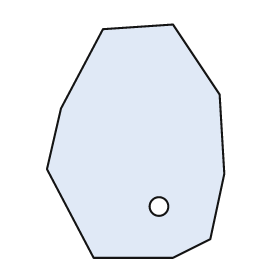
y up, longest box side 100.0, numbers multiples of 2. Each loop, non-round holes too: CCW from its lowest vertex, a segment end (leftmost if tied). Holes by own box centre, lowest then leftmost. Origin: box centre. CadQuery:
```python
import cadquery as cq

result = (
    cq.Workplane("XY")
    .moveTo(-18.0, -50.0)
    .lineTo(16.0, -50.0)
    .lineTo(32.0, -42.0)
    .lineTo(38.0, -14.0)
    .lineTo(36.0, 20.0)
    .lineTo(16.0, 50.0)
    .lineTo(-14.0, 48.0)
    .lineTo(-32.0, 14.0)
    .lineTo(-38.0, -12.0)
    .close()
    .moveTo(10.0, -28.0)
    .circle(4.0)
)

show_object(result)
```